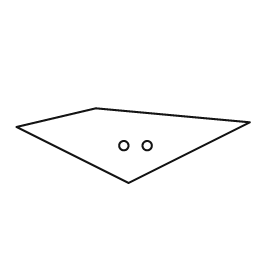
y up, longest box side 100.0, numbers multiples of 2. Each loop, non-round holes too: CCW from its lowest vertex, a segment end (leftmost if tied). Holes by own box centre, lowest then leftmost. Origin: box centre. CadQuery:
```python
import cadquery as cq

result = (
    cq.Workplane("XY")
    .moveTo(-2.0, -16.0)
    .lineTo(50.0, 10.0)
    .lineTo(-16.0, 16.0)
    .lineTo(-50.0, 8.0)
    .close()
    .moveTo(-4.0, 0.0)
    .circle(2.0)
    .moveTo(6.0, 0.0)
    .circle(2.0)
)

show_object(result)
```